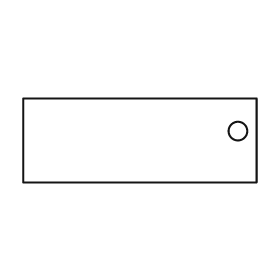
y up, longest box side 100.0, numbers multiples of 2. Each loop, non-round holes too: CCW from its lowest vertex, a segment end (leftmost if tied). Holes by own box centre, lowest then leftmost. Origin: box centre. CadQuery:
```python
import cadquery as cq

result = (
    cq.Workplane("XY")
    .moveTo(-50.0, -18.0)
    .lineTo(50.0, -18.0)
    .lineTo(50.0, 18.0)
    .lineTo(-50.0, 18.0)
    .close()
    .moveTo(42.0, 4.0)
    .circle(4.0)
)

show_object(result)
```